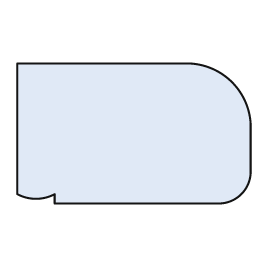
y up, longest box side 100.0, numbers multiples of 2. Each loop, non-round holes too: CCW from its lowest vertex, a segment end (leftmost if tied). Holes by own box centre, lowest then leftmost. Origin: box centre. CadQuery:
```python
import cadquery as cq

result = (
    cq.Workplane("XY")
    .moveTo(-34.0, -30.0)
    .lineTo(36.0, -30.0)
    .threePointArc((46.0, -26.0), (50.0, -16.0))
    .lineTo(50.0, 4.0)
    .threePointArc((42.0, 22.0), (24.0, 30.0))
    .lineTo(-50.0, 30.0)
    .lineTo(-50.0, -26.0)
    .threePointArc((-42.0, -28.0), (-34.0, -26.0))
    .close()
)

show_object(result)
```